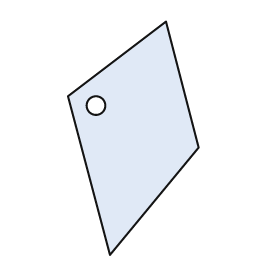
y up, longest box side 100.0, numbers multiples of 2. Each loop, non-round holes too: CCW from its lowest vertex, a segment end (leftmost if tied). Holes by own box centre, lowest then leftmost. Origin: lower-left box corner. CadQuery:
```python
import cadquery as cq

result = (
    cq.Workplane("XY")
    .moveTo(18.0, 0.0)
    .lineTo(56.0, 46.0)
    .lineTo(42.0, 100.0)
    .lineTo(0.0, 68.0)
    .close()
    .moveTo(12.0, 64.0)
    .circle(4.0)
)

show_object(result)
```